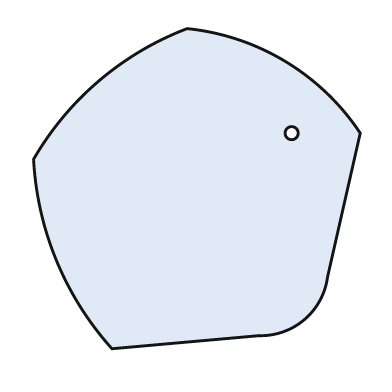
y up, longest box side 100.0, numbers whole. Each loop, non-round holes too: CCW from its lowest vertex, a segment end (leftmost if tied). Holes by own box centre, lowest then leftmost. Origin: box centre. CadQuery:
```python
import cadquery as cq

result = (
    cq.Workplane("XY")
    .moveTo(-26.0, -49.0)
    .lineTo(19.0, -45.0)
    .threePointArc((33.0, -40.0), (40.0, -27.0))
    .lineTo(50.0, 17.0)
    .threePointArc((27.0, 39.0), (-3.0, 49.0))
    .threePointArc((-30.0, 33.0), (-50.0, 9.0))
    .threePointArc((-43.0, -22.0), (-26.0, -49.0))
    .close()
    .moveTo(29.0, 17.0)
    .circle(2.0)
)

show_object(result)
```